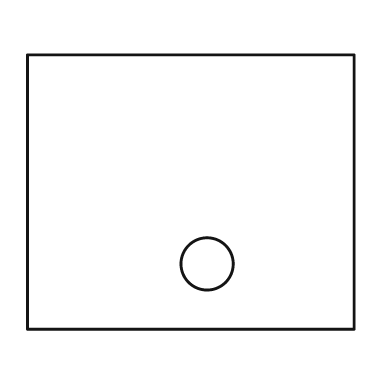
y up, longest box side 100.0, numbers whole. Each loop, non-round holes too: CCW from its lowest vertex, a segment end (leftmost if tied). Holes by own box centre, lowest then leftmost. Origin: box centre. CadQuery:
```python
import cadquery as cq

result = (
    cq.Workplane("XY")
    .moveTo(-50.0, -42.0)
    .lineTo(50.0, -42.0)
    .lineTo(50.0, 42.0)
    .lineTo(-50.0, 42.0)
    .close()
    .moveTo(5.0, -22.0)
    .circle(8.0)
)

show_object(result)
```